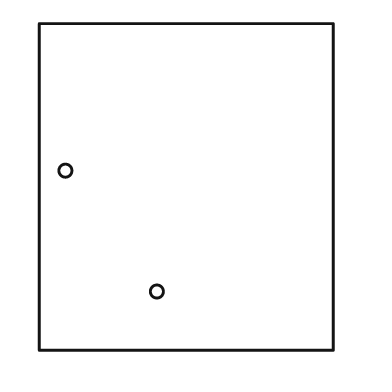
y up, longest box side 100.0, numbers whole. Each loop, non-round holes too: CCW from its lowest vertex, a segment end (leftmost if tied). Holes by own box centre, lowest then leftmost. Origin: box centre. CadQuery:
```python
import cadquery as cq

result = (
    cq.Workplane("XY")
    .moveTo(-45.0, -50.0)
    .lineTo(45.0, -50.0)
    .lineTo(45.0, 50.0)
    .lineTo(-45.0, 50.0)
    .close()
    .moveTo(-9.0, -32.0)
    .circle(2.0)
    .moveTo(-37.0, 5.0)
    .circle(2.0)
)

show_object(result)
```